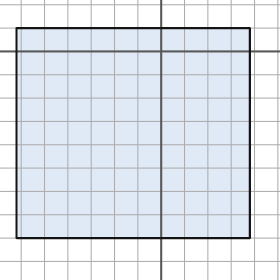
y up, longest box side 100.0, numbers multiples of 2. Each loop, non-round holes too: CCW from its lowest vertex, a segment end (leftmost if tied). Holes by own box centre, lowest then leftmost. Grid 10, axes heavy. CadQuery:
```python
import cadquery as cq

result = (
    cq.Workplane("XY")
    .moveTo(-62.0, -80.0)
    .lineTo(38.0, -80.0)
    .lineTo(38.0, 10.0)
    .lineTo(-62.0, 10.0)
    .close()
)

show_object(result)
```